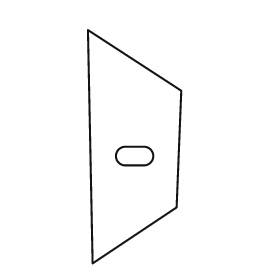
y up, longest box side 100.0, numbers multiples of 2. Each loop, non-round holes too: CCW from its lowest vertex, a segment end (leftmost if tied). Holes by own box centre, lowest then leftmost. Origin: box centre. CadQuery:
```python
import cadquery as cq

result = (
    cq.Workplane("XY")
    .moveTo(-18.0, -50.0)
    .lineTo(18.0, -26.0)
    .lineTo(20.0, 24.0)
    .lineTo(-20.0, 50.0)
    .close()
    .moveTo(-4.0, -8.0)
    .lineTo(4.0, -8.0)
    .threePointArc((8.0, -4.0), (4.0, 0.0))
    .lineTo(-4.0, 0.0)
    .threePointArc((-8.0, -4.0), (-4.0, -8.0))
    .close()
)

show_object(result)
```